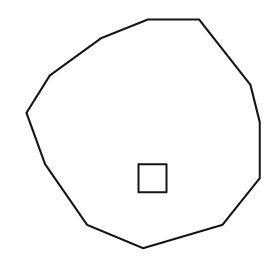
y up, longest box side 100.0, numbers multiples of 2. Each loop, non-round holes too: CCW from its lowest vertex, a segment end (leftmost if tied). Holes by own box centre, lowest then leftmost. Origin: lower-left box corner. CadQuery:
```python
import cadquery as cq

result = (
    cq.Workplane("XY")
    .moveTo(50.0, 0.0)
    .lineTo(84.0, 10.0)
    .lineTo(100.0, 30.0)
    .lineTo(100.0, 54.0)
    .lineTo(96.0, 70.0)
    .lineTo(74.0, 98.0)
    .lineTo(52.0, 98.0)
    .lineTo(32.0, 90.0)
    .lineTo(10.0, 74.0)
    .lineTo(0.0, 58.0)
    .lineTo(8.0, 36.0)
    .lineTo(26.0, 10.0)
    .close()
    .moveTo(48.0, 24.0)
    .lineTo(60.0, 24.0)
    .lineTo(60.0, 36.0)
    .lineTo(48.0, 36.0)
    .close()
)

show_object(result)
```